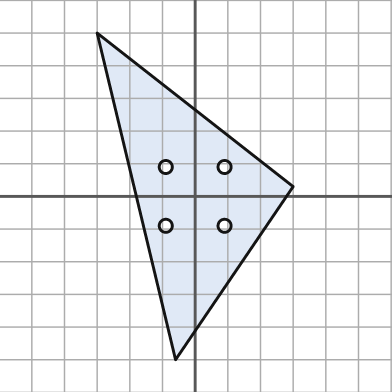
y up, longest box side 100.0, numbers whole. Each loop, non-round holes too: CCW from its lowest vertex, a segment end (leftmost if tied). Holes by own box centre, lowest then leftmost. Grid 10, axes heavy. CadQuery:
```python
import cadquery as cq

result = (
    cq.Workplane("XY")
    .moveTo(-6.0, -50.0)
    .lineTo(30.0, 3.0)
    .lineTo(-30.0, 50.0)
    .close()
    .moveTo(-9.0, -9.0)
    .circle(2.0)
    .moveTo(9.0, -9.0)
    .circle(2.0)
    .moveTo(-9.0, 9.0)
    .circle(2.0)
    .moveTo(9.0, 9.0)
    .circle(2.0)
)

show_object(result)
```